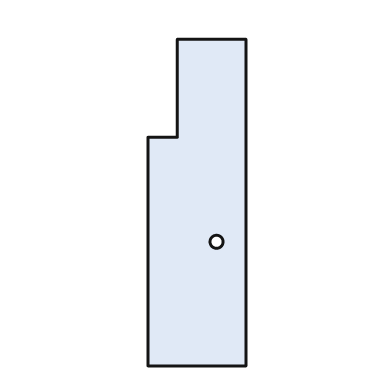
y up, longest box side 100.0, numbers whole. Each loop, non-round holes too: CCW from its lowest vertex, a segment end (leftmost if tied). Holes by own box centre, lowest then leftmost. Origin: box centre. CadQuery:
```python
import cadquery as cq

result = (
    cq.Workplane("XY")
    .moveTo(-15.0, -50.0)
    .lineTo(15.0, -50.0)
    .lineTo(15.0, 50.0)
    .lineTo(-6.0, 50.0)
    .lineTo(-6.0, 20.0)
    .lineTo(-15.0, 20.0)
    .close()
    .moveTo(6.0, -12.0)
    .circle(2.0)
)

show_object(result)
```